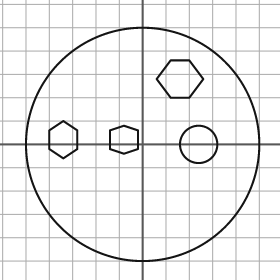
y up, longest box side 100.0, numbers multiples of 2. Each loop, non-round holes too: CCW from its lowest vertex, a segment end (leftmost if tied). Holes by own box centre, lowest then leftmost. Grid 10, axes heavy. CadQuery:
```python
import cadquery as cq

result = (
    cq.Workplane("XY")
    .moveTo(0.0, 0.0)
    .circle(50.0)
    .moveTo(24.0, 0.0)
    .circle(8.0)
    .moveTo(-34.0, -6.0)
    .lineTo(-28.0, -2.0)
    .lineTo(-28.0, 6.0)
    .lineTo(-34.0, 10.0)
    .lineTo(-40.0, 6.0)
    .lineTo(-40.0, -2.0)
    .close()
    .moveTo(-8.0, -4.0)
    .lineTo(-2.0, -2.0)
    .lineTo(-2.0, 6.0)
    .lineTo(-8.0, 8.0)
    .lineTo(-14.0, 6.0)
    .lineTo(-14.0, -2.0)
    .close()
    .moveTo(12.0, 20.0)
    .lineTo(20.0, 20.0)
    .lineTo(26.0, 28.0)
    .lineTo(20.0, 36.0)
    .lineTo(12.0, 36.0)
    .lineTo(6.0, 28.0)
    .close()
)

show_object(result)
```